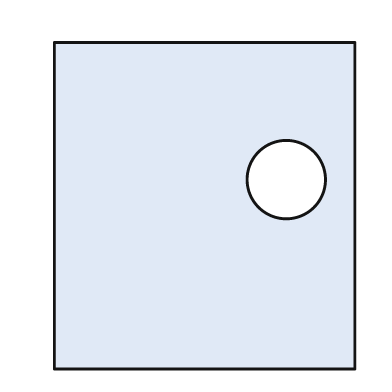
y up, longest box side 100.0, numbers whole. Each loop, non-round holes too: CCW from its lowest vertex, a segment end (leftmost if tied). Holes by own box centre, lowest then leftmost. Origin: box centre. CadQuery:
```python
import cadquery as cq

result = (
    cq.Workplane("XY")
    .moveTo(-46.0, -50.0)
    .lineTo(46.0, -50.0)
    .lineTo(46.0, 50.0)
    .lineTo(-46.0, 50.0)
    .close()
    .moveTo(25.0, 8.0)
    .circle(12.0)
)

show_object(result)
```